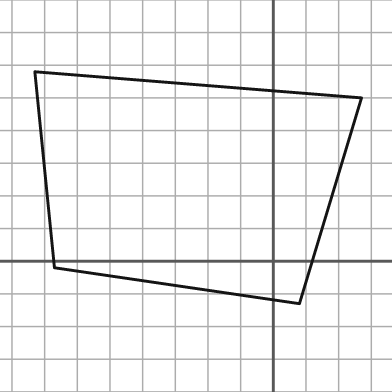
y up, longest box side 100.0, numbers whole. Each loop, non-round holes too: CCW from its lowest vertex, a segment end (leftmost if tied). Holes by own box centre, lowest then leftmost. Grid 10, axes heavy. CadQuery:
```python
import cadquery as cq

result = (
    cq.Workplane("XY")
    .moveTo(8.0, -13.0)
    .lineTo(27.0, 50.0)
    .lineTo(-73.0, 58.0)
    .lineTo(-67.0, -2.0)
    .close()
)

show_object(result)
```